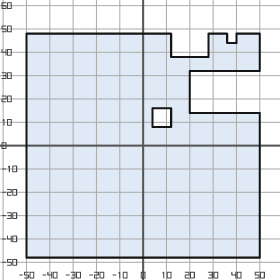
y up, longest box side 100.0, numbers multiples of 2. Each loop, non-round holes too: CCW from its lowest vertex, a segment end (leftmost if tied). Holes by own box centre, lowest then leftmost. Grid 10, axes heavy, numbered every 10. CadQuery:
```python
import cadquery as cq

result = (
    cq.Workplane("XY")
    .moveTo(-50.0, -48.0)
    .lineTo(50.0, -48.0)
    .lineTo(50.0, 14.0)
    .lineTo(20.0, 14.0)
    .lineTo(20.0, 32.0)
    .lineTo(50.0, 32.0)
    .lineTo(50.0, 48.0)
    .lineTo(40.0, 48.0)
    .lineTo(40.0, 44.0)
    .lineTo(36.0, 44.0)
    .lineTo(36.0, 48.0)
    .lineTo(28.0, 48.0)
    .lineTo(28.0, 38.0)
    .lineTo(12.0, 38.0)
    .lineTo(12.0, 48.0)
    .lineTo(-50.0, 48.0)
    .close()
    .moveTo(4.0, 8.0)
    .lineTo(12.0, 8.0)
    .lineTo(12.0, 16.0)
    .lineTo(4.0, 16.0)
    .close()
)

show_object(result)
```